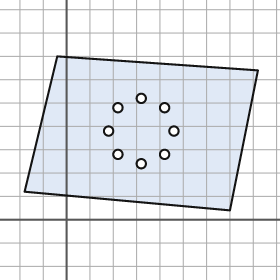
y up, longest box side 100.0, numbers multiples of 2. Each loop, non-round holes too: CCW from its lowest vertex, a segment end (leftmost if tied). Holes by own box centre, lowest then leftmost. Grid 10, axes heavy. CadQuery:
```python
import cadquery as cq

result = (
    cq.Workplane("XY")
    .moveTo(70.0, 4.0)
    .lineTo(82.0, 64.0)
    .lineTo(-4.0, 70.0)
    .lineTo(-18.0, 12.0)
    .close()
    .moveTo(32.0, 24.0)
    .circle(2.0)
    .moveTo(22.0, 28.0)
    .circle(2.0)
    .moveTo(42.0, 28.0)
    .circle(2.0)
    .moveTo(18.0, 38.0)
    .circle(2.0)
    .moveTo(46.0, 38.0)
    .circle(2.0)
    .moveTo(22.0, 48.0)
    .circle(2.0)
    .moveTo(42.0, 48.0)
    .circle(2.0)
    .moveTo(32.0, 52.0)
    .circle(2.0)
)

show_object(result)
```